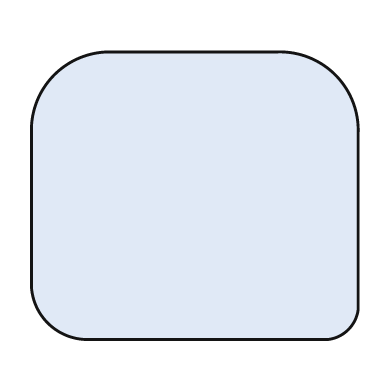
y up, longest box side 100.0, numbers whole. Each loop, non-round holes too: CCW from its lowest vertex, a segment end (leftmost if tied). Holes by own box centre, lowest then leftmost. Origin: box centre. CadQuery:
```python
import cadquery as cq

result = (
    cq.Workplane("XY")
    .moveTo(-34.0, -44.0)
    .lineTo(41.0, -44.0)
    .threePointArc((47.0, -41.0), (50.0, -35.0))
    .lineTo(50.0, 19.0)
    .threePointArc((43.0, 37.0), (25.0, 44.0))
    .lineTo(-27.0, 44.0)
    .threePointArc((-43.0, 37.0), (-50.0, 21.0))
    .lineTo(-50.0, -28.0)
    .threePointArc((-45.0, -39.0), (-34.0, -44.0))
    .close()
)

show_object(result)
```